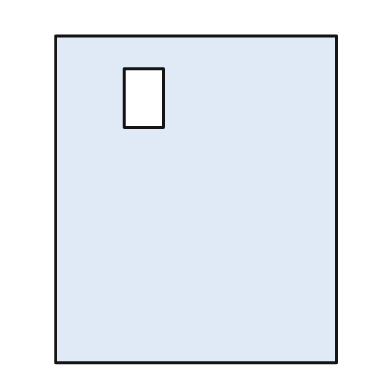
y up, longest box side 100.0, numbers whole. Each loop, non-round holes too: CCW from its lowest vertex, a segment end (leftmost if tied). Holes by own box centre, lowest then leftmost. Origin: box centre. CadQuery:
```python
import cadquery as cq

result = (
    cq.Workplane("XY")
    .moveTo(-43.0, -50.0)
    .lineTo(43.0, -50.0)
    .lineTo(43.0, 50.0)
    .lineTo(-43.0, 50.0)
    .close()
    .moveTo(-22.0, 22.0)
    .lineTo(-10.0, 22.0)
    .lineTo(-10.0, 40.0)
    .lineTo(-22.0, 40.0)
    .close()
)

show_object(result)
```